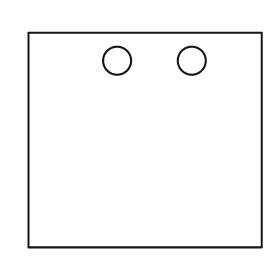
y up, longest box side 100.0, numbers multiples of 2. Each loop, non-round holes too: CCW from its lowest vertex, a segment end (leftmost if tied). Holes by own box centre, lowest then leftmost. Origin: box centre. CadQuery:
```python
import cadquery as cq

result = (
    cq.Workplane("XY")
    .moveTo(-50.0, -46.0)
    .lineTo(50.0, -46.0)
    .lineTo(50.0, 46.0)
    .lineTo(-50.0, 46.0)
    .close()
    .moveTo(-12.0, 34.0)
    .circle(6.0)
    .moveTo(20.0, 34.0)
    .circle(6.0)
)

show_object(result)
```